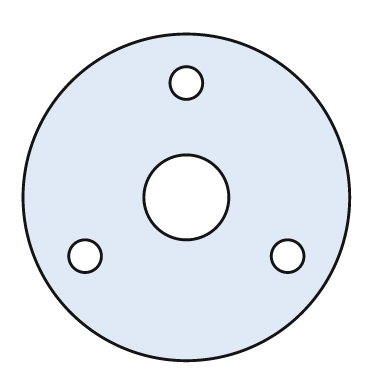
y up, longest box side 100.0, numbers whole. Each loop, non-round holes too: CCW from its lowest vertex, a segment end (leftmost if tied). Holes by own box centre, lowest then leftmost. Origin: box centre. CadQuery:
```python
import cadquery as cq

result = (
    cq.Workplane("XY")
    .moveTo(0.0, 0.0)
    .circle(50.0)
    .moveTo(-31.0, -18.0)
    .circle(5.0)
    .moveTo(31.0, -18.0)
    .circle(5.0)
    .moveTo(0.0, 0.0)
    .circle(13.0)
    .moveTo(0.0, 35.0)
    .circle(5.0)
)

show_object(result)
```